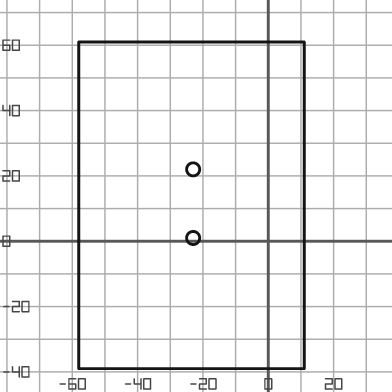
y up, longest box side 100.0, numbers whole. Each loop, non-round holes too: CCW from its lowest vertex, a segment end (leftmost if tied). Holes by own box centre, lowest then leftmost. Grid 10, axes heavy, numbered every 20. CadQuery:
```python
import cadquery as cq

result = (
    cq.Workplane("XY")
    .moveTo(-58.0, -39.0)
    .lineTo(11.0, -39.0)
    .lineTo(11.0, 61.0)
    .lineTo(-58.0, 61.0)
    .close()
    .moveTo(-23.0, 1.0)
    .circle(2.0)
    .moveTo(-23.0, 22.0)
    .circle(2.0)
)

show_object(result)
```